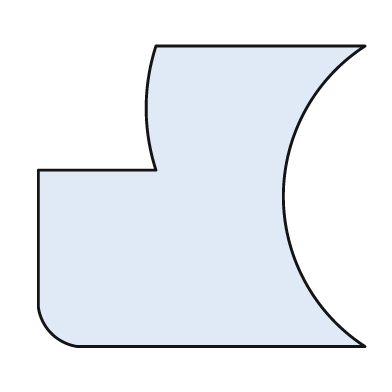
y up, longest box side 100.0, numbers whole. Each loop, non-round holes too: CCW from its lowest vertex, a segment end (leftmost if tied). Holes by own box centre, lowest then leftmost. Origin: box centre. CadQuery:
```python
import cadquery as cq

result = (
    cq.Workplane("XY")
    .moveTo(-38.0, -46.0)
    .lineTo(50.0, -46.0)
    .threePointArc((25.0, 0.0), (50.0, 46.0))
    .lineTo(-14.0, 46.0)
    .threePointArc((-17.0, 27.0), (-14.0, 8.0))
    .lineTo(-50.0, 8.0)
    .lineTo(-50.0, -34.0)
    .threePointArc((-46.0, -42.0), (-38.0, -46.0))
    .close()
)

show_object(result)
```